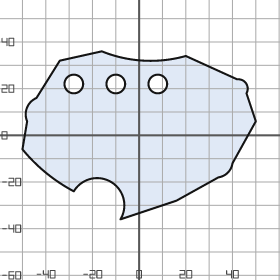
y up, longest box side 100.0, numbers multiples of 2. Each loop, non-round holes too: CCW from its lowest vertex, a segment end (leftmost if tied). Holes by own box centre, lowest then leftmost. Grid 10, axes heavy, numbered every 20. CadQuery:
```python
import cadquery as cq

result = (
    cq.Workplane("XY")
    .moveTo(-8.0, -36.0)
    .lineTo(16.0, -28.0)
    .lineTo(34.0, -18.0)
    .threePointArc((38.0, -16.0), (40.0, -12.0))
    .lineTo(50.0, 6.0)
    .lineTo(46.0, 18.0)
    .threePointArc((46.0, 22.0), (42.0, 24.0))
    .lineTo(20.0, 34.0)
    .threePointArc((2.0, 32.0), (-16.0, 36.0))
    .lineTo(-34.0, 32.0)
    .lineTo(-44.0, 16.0)
    .threePointArc((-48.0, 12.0), (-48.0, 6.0))
    .lineTo(-50.0, -6.0)
    .threePointArc((-40.0, -16.0), (-28.0, -24.0))
    .threePointArc((-12.0, -20.0), (-8.0, -36.0))
    .close()
    .moveTo(-28.0, 22.0)
    .circle(4.0)
    .moveTo(-10.0, 22.0)
    .circle(4.0)
    .moveTo(8.0, 22.0)
    .circle(4.0)
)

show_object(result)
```